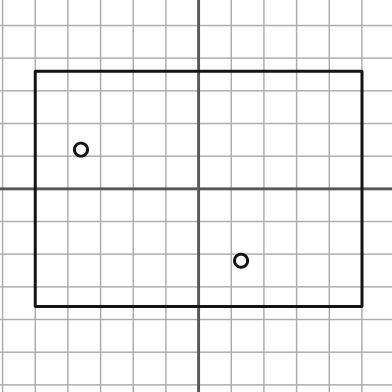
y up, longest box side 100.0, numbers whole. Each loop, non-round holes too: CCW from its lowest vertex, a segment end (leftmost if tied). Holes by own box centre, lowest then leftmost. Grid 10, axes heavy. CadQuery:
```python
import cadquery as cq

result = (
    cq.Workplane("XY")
    .moveTo(-50.0, -36.0)
    .lineTo(50.0, -36.0)
    .lineTo(50.0, 36.0)
    .lineTo(-50.0, 36.0)
    .close()
    .moveTo(13.0, -22.0)
    .circle(2.0)
    .moveTo(-36.0, 12.0)
    .circle(2.0)
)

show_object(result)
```